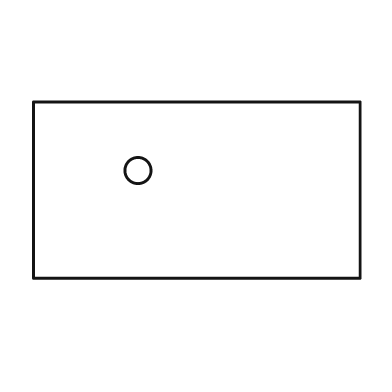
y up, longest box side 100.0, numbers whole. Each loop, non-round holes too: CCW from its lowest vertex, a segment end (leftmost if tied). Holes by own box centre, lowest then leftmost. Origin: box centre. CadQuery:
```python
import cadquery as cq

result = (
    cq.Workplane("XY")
    .moveTo(-50.0, -27.0)
    .lineTo(50.0, -27.0)
    .lineTo(50.0, 27.0)
    .lineTo(-50.0, 27.0)
    .close()
    .moveTo(-18.0, 6.0)
    .circle(4.0)
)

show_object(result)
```